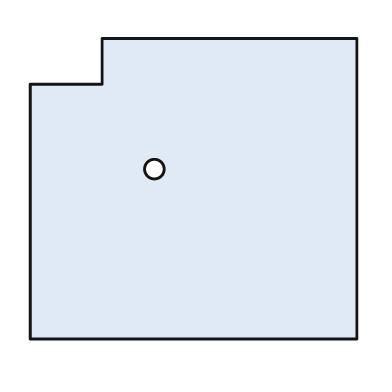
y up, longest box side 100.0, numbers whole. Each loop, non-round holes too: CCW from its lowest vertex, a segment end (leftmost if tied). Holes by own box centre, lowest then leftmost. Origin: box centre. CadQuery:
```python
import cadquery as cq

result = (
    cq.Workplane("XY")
    .moveTo(-50.0, -46.0)
    .lineTo(50.0, -46.0)
    .lineTo(50.0, 46.0)
    .lineTo(-28.0, 46.0)
    .lineTo(-28.0, 32.0)
    .lineTo(-50.0, 32.0)
    .close()
    .moveTo(-12.0, 6.0)
    .circle(3.0)
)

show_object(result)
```